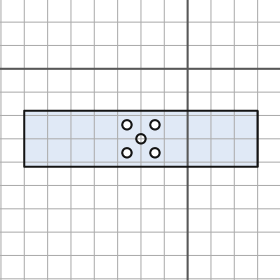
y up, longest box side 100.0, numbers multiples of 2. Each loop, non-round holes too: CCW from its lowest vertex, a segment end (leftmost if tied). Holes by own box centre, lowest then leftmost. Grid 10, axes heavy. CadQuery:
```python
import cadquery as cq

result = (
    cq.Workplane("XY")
    .moveTo(-70.0, -42.0)
    .lineTo(30.0, -42.0)
    .lineTo(30.0, -18.0)
    .lineTo(-70.0, -18.0)
    .close()
    .moveTo(-26.0, -36.0)
    .circle(2.0)
    .moveTo(-14.0, -36.0)
    .circle(2.0)
    .moveTo(-20.0, -30.0)
    .circle(2.0)
    .moveTo(-26.0, -24.0)
    .circle(2.0)
    .moveTo(-14.0, -24.0)
    .circle(2.0)
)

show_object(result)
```